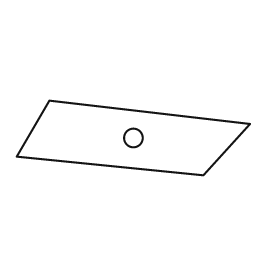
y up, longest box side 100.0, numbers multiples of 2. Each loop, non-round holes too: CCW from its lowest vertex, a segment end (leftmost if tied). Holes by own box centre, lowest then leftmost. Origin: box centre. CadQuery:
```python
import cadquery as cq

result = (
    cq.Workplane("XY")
    .moveTo(30.0, -16.0)
    .lineTo(50.0, 6.0)
    .lineTo(-36.0, 16.0)
    .lineTo(-50.0, -8.0)
    .close()
    .moveTo(0.0, 0.0)
    .circle(4.0)
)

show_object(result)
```